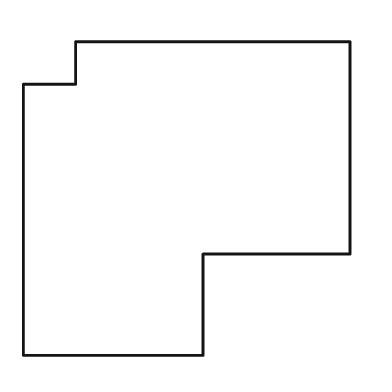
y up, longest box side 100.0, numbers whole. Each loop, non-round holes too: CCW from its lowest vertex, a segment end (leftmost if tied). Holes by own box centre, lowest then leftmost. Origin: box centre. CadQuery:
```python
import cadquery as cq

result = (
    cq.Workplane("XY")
    .moveTo(-50.0, -48.0)
    .lineTo(5.0, -48.0)
    .lineTo(5.0, -17.0)
    .lineTo(50.0, -17.0)
    .lineTo(50.0, 48.0)
    .lineTo(-34.0, 48.0)
    .lineTo(-34.0, 35.0)
    .lineTo(-50.0, 35.0)
    .close()
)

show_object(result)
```